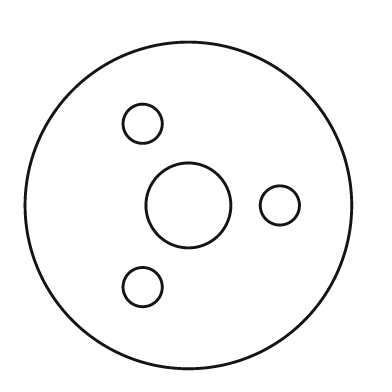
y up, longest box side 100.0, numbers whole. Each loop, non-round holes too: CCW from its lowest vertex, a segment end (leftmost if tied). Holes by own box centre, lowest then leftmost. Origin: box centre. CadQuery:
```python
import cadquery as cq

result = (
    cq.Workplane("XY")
    .moveTo(0.0, 0.0)
    .circle(50.0)
    .moveTo(-14.0, -25.0)
    .circle(6.0)
    .moveTo(0.0, 0.0)
    .circle(13.0)
    .moveTo(28.0, 0.0)
    .circle(6.0)
    .moveTo(-14.0, 25.0)
    .circle(6.0)
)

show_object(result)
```